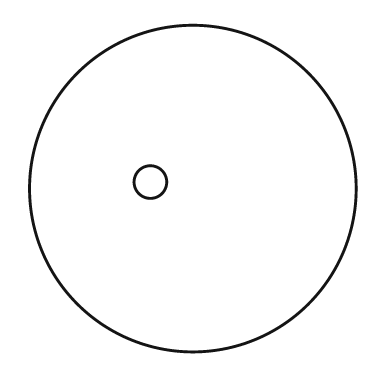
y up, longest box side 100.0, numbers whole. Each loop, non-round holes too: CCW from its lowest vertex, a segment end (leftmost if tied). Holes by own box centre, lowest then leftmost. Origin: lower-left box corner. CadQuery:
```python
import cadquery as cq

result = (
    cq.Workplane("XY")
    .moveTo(50.0, 50.0)
    .circle(50.0)
    .moveTo(37.0, 52.0)
    .circle(5.0)
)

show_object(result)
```